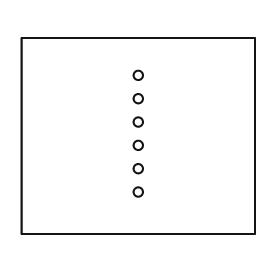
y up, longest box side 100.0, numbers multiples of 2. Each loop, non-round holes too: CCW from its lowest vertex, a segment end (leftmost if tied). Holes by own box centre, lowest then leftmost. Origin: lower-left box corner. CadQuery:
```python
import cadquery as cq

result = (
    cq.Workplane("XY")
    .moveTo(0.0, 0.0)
    .lineTo(100.0, 0.0)
    .lineTo(100.0, 84.0)
    .lineTo(0.0, 84.0)
    .close()
    .moveTo(50.0, 18.0)
    .circle(2.0)
    .moveTo(50.0, 28.0)
    .circle(2.0)
    .moveTo(50.0, 38.0)
    .circle(2.0)
    .moveTo(50.0, 48.0)
    .circle(2.0)
    .moveTo(50.0, 58.0)
    .circle(2.0)
    .moveTo(50.0, 68.0)
    .circle(2.0)
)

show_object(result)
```